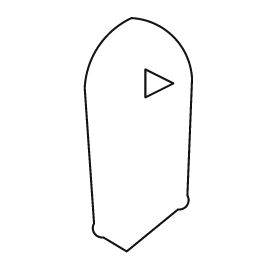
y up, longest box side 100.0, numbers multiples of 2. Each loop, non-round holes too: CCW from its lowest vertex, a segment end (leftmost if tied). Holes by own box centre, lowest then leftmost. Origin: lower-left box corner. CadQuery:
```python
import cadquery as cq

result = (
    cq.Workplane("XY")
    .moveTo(18.0, 0.0)
    .lineTo(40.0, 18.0)
    .threePointArc((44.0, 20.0), (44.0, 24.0))
    .lineTo(46.0, 74.0)
    .threePointArc((38.0, 92.0), (20.0, 100.0))
    .threePointArc((6.0, 88.0), (0.0, 70.0))
    .lineTo(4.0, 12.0)
    .threePointArc((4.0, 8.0), (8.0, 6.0))
    .close()
    .moveTo(26.0, 66.0)
    .lineTo(38.0, 72.0)
    .lineTo(26.0, 78.0)
    .close()
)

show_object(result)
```